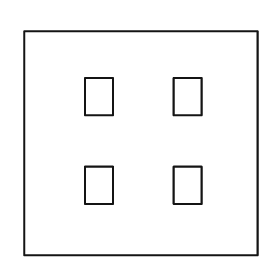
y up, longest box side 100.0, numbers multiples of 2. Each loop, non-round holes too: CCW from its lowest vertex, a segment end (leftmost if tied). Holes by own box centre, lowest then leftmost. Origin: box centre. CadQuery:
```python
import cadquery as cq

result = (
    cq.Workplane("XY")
    .moveTo(-50.0, -48.0)
    .lineTo(50.0, -48.0)
    .lineTo(50.0, 48.0)
    .lineTo(-50.0, 48.0)
    .close()
    .moveTo(-24.0, -26.0)
    .lineTo(-12.0, -26.0)
    .lineTo(-12.0, -10.0)
    .lineTo(-24.0, -10.0)
    .close()
    .moveTo(14.0, -26.0)
    .lineTo(26.0, -26.0)
    .lineTo(26.0, -10.0)
    .lineTo(14.0, -10.0)
    .close()
    .moveTo(-24.0, 12.0)
    .lineTo(-12.0, 12.0)
    .lineTo(-12.0, 28.0)
    .lineTo(-24.0, 28.0)
    .close()
    .moveTo(14.0, 12.0)
    .lineTo(26.0, 12.0)
    .lineTo(26.0, 28.0)
    .lineTo(14.0, 28.0)
    .close()
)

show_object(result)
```